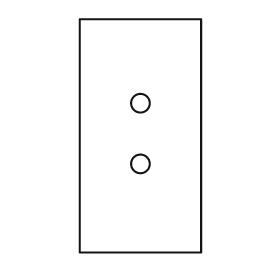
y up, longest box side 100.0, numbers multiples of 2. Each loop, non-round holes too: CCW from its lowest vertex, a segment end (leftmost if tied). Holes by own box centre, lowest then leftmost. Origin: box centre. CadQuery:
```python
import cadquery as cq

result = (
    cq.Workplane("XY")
    .moveTo(-26.0, -50.0)
    .lineTo(26.0, -50.0)
    .lineTo(26.0, 50.0)
    .lineTo(-26.0, 50.0)
    .close()
    .moveTo(0.0, -12.0)
    .circle(4.0)
    .moveTo(0.0, 14.0)
    .circle(4.0)
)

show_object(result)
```